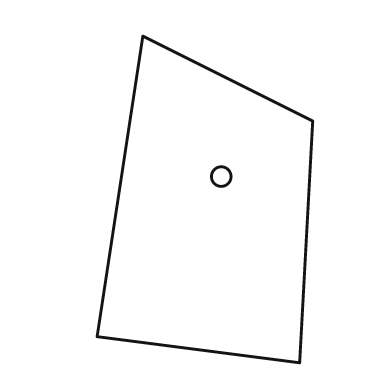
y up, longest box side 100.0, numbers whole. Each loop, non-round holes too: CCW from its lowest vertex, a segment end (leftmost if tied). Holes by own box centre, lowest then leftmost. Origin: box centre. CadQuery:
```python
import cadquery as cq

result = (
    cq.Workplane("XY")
    .moveTo(29.0, -50.0)
    .lineTo(33.0, 24.0)
    .lineTo(-19.0, 50.0)
    .lineTo(-33.0, -42.0)
    .close()
    .moveTo(5.0, 7.0)
    .circle(3.0)
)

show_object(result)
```